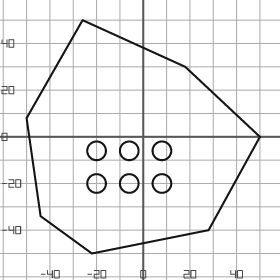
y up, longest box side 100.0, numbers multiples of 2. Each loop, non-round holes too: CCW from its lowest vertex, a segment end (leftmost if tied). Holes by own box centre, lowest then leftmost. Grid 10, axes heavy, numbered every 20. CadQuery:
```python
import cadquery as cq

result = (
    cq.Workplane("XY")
    .moveTo(-22.0, -50.0)
    .lineTo(28.0, -40.0)
    .lineTo(50.0, 0.0)
    .lineTo(18.0, 30.0)
    .lineTo(-26.0, 50.0)
    .lineTo(-50.0, 8.0)
    .lineTo(-44.0, -34.0)
    .close()
    .moveTo(-20.0, -20.0)
    .circle(4.0)
    .moveTo(-6.0, -20.0)
    .circle(4.0)
    .moveTo(8.0, -20.0)
    .circle(4.0)
    .moveTo(-20.0, -6.0)
    .circle(4.0)
    .moveTo(-6.0, -6.0)
    .circle(4.0)
    .moveTo(8.0, -6.0)
    .circle(4.0)
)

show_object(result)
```